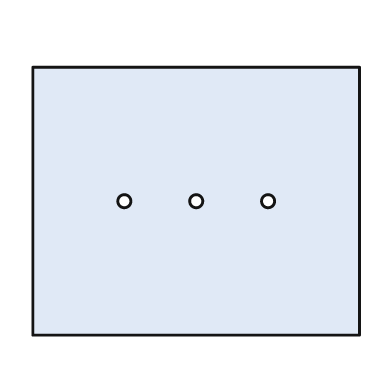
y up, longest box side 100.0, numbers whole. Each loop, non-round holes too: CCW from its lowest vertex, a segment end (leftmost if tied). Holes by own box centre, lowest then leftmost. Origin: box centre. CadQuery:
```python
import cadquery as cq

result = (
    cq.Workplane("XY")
    .moveTo(-50.0, -41.0)
    .lineTo(50.0, -41.0)
    .lineTo(50.0, 41.0)
    .lineTo(-50.0, 41.0)
    .close()
    .moveTo(-22.0, 0.0)
    .circle(2.0)
    .moveTo(0.0, 0.0)
    .circle(2.0)
    .moveTo(22.0, 0.0)
    .circle(2.0)
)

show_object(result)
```